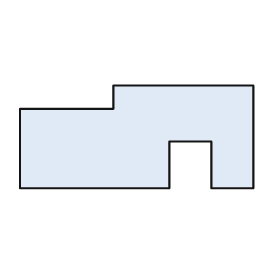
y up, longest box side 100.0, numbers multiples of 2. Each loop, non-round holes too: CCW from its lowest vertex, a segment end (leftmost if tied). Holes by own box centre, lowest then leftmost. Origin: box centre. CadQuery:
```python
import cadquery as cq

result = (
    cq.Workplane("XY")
    .moveTo(-50.0, -22.0)
    .lineTo(14.0, -22.0)
    .lineTo(14.0, -2.0)
    .lineTo(32.0, -2.0)
    .lineTo(32.0, -22.0)
    .lineTo(50.0, -22.0)
    .lineTo(50.0, 22.0)
    .lineTo(-10.0, 22.0)
    .lineTo(-10.0, 12.0)
    .lineTo(-50.0, 12.0)
    .close()
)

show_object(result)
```